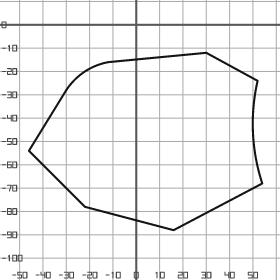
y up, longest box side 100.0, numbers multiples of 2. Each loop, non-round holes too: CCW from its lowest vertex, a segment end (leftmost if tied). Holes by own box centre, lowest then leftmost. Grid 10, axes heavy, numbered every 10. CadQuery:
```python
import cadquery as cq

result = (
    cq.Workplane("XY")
    .moveTo(16.0, -88.0)
    .lineTo(54.0, -68.0)
    .threePointArc((50.0, -46.0), (52.0, -24.0))
    .lineTo(30.0, -12.0)
    .lineTo(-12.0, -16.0)
    .threePointArc((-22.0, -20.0), (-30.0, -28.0))
    .lineTo(-46.0, -54.0)
    .lineTo(-22.0, -78.0)
    .close()
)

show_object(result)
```